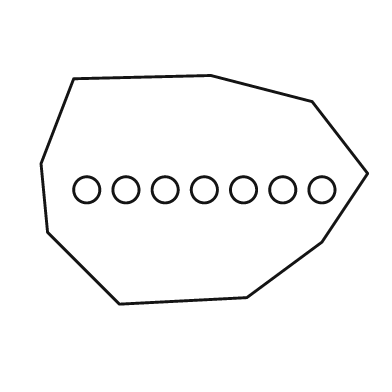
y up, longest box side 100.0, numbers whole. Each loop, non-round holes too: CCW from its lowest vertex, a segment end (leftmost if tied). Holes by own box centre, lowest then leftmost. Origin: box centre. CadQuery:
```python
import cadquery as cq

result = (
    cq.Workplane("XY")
    .moveTo(-26.0, -35.0)
    .lineTo(13.0, -33.0)
    .lineTo(36.0, -16.0)
    .lineTo(50.0, 5.0)
    .lineTo(33.0, 27.0)
    .lineTo(2.0, 35.0)
    .lineTo(-40.0, 34.0)
    .lineTo(-50.0, 8.0)
    .lineTo(-48.0, -13.0)
    .close()
    .moveTo(-36.0, 0.0)
    .circle(4.0)
    .moveTo(-24.0, 0.0)
    .circle(4.0)
    .moveTo(-12.0, 0.0)
    .circle(4.0)
    .moveTo(0.0, 0.0)
    .circle(4.0)
    .moveTo(12.0, 0.0)
    .circle(4.0)
    .moveTo(24.0, 0.0)
    .circle(4.0)
    .moveTo(36.0, 0.0)
    .circle(4.0)
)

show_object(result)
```